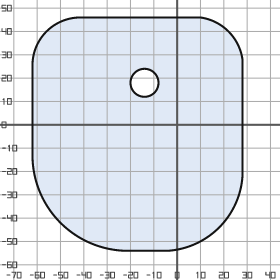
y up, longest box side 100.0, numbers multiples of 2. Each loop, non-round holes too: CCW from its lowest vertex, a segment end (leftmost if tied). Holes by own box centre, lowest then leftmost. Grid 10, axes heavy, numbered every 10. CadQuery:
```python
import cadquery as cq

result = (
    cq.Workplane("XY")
    .moveTo(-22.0, -54.0)
    .lineTo(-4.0, -54.0)
    .threePointArc((18.0, -44.0), (28.0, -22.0))
    .lineTo(28.0, 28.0)
    .threePointArc((22.0, 40.0), (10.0, 46.0))
    .lineTo(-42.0, 46.0)
    .threePointArc((-56.0, 40.0), (-62.0, 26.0))
    .lineTo(-62.0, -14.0)
    .threePointArc((-50.0, -42.0), (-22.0, -54.0))
    .close()
    .moveTo(-14.0, 18.0)
    .circle(6.0)
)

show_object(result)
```